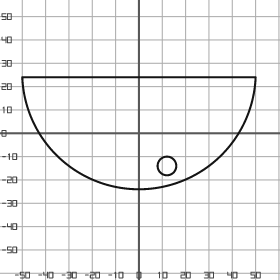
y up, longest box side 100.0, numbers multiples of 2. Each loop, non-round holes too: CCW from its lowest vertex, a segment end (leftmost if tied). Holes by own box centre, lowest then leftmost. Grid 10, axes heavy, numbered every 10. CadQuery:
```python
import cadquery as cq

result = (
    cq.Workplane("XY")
    .moveTo(-50.0, 24.0)
    .threePointArc((0.0, -24.0), (50.0, 24.0))
    .close()
    .moveTo(12.0, -14.0)
    .circle(4.0)
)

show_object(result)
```